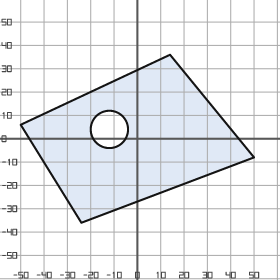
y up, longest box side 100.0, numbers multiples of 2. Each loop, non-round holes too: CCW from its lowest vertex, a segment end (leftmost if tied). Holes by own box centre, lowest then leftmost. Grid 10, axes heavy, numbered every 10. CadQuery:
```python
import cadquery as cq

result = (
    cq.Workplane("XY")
    .moveTo(-24.0, -36.0)
    .lineTo(50.0, -8.0)
    .lineTo(14.0, 36.0)
    .lineTo(-50.0, 6.0)
    .close()
    .moveTo(-12.0, 4.0)
    .circle(8.0)
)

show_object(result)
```